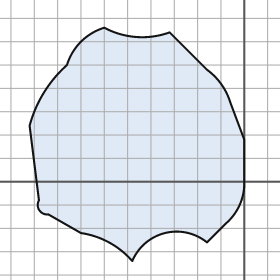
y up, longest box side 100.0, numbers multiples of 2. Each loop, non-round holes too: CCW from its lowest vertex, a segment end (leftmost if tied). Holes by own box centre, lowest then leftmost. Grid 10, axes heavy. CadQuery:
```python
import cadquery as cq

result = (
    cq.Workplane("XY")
    .moveTo(-48.0, -34.0)
    .threePointArc((-34.0, -22.0), (-16.0, -26.0))
    .lineTo(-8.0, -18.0)
    .threePointArc((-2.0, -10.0), (0.0, 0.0))
    .lineTo(0.0, 18.0)
    .lineTo(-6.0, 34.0)
    .threePointArc((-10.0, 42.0), (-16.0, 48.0))
    .lineTo(-32.0, 64.0)
    .threePointArc((-46.0, 62.0), (-60.0, 66.0))
    .threePointArc((-70.0, 60.0), (-76.0, 50.0))
    .threePointArc((-86.0, 38.0), (-92.0, 24.0))
    .lineTo(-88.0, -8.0)
    .threePointArc((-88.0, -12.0), (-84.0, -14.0))
    .lineTo(-70.0, -22.0)
    .threePointArc((-58.0, -26.0), (-48.0, -34.0))
    .close()
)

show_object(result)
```